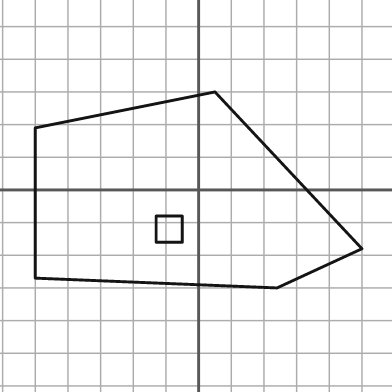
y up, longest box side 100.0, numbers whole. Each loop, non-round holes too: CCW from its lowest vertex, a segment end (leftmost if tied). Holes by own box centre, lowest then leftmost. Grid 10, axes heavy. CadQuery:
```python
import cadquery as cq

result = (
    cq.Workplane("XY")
    .moveTo(24.0, -30.0)
    .lineTo(50.0, -18.0)
    .lineTo(5.0, 30.0)
    .lineTo(-50.0, 19.0)
    .lineTo(-50.0, -27.0)
    .close()
    .moveTo(-13.0, -16.0)
    .lineTo(-5.0, -16.0)
    .lineTo(-5.0, -8.0)
    .lineTo(-13.0, -8.0)
    .close()
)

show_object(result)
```